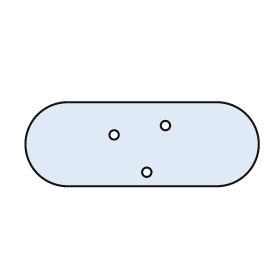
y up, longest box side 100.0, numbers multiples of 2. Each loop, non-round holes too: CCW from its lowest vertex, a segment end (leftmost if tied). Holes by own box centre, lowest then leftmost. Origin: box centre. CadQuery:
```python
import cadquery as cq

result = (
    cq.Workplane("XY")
    .moveTo(-32.0, -18.0)
    .lineTo(32.0, -18.0)
    .threePointArc((50.0, 0.0), (32.0, 18.0))
    .lineTo(-32.0, 18.0)
    .threePointArc((-50.0, 0.0), (-32.0, -18.0))
    .close()
    .moveTo(2.0, -12.0)
    .circle(2.0)
    .moveTo(-12.0, 4.0)
    .circle(2.0)
    .moveTo(10.0, 8.0)
    .circle(2.0)
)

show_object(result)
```